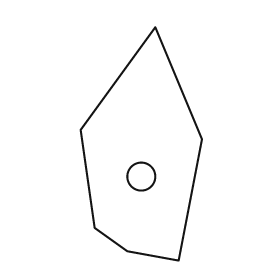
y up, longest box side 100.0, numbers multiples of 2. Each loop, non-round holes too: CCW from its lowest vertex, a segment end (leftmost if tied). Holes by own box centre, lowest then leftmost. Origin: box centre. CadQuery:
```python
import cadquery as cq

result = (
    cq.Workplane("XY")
    .moveTo(16.0, -50.0)
    .lineTo(26.0, 2.0)
    .lineTo(6.0, 50.0)
    .lineTo(-26.0, 6.0)
    .lineTo(-20.0, -36.0)
    .lineTo(-6.0, -46.0)
    .close()
    .moveTo(0.0, -14.0)
    .circle(6.0)
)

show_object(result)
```